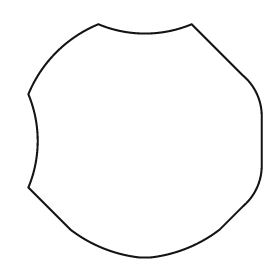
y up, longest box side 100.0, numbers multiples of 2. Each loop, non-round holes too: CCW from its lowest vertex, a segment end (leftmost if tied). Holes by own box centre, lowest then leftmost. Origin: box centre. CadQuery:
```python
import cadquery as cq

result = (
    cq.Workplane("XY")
    .moveTo(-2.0, -50.0)
    .lineTo(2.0, -50.0)
    .threePointArc((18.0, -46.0), (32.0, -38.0))
    .lineTo(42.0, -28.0)
    .threePointArc((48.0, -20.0), (50.0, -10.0))
    .lineTo(50.0, 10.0)
    .threePointArc((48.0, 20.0), (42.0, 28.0))
    .lineTo(20.0, 50.0)
    .threePointArc((0.0, 46.0), (-20.0, 50.0))
    .threePointArc((-38.0, 38.0), (-50.0, 20.0))
    .threePointArc((-46.0, 0.0), (-50.0, -20.0))
    .lineTo(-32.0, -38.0)
    .threePointArc((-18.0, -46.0), (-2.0, -50.0))
    .close()
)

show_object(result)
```